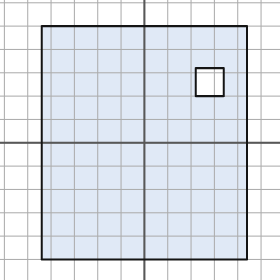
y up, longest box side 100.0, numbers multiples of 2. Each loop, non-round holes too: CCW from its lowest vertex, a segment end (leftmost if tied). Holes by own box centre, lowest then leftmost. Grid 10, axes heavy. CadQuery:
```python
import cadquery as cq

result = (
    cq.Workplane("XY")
    .moveTo(-44.0, -50.0)
    .lineTo(44.0, -50.0)
    .lineTo(44.0, 50.0)
    .lineTo(-44.0, 50.0)
    .close()
    .moveTo(22.0, 20.0)
    .lineTo(34.0, 20.0)
    .lineTo(34.0, 32.0)
    .lineTo(22.0, 32.0)
    .close()
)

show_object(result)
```